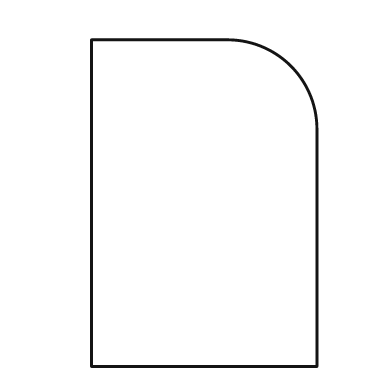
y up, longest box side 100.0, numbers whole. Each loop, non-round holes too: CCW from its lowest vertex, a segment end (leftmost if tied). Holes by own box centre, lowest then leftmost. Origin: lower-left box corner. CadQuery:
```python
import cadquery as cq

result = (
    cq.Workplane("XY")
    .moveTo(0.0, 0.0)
    .lineTo(69.0, 0.0)
    .lineTo(69.0, 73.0)
    .threePointArc((61.0, 92.0), (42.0, 100.0))
    .lineTo(0.0, 100.0)
    .close()
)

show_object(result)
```